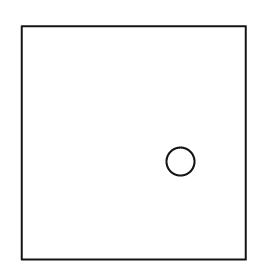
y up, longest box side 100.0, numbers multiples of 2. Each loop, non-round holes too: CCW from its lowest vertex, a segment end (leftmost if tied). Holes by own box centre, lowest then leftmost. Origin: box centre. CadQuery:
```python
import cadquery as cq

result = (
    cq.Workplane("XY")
    .moveTo(-48.0, -50.0)
    .lineTo(48.0, -50.0)
    .lineTo(48.0, 50.0)
    .lineTo(-48.0, 50.0)
    .close()
    .moveTo(20.0, -8.0)
    .circle(6.0)
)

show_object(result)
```